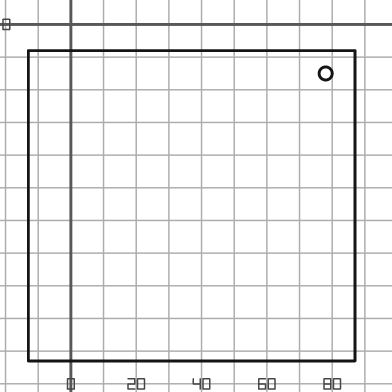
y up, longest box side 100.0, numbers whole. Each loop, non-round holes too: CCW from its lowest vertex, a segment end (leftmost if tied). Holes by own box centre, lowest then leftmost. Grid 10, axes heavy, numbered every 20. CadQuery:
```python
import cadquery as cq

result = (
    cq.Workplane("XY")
    .moveTo(-13.0, -103.0)
    .lineTo(87.0, -103.0)
    .lineTo(87.0, -8.0)
    .lineTo(-13.0, -8.0)
    .close()
    .moveTo(78.0, -15.0)
    .circle(2.0)
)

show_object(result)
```